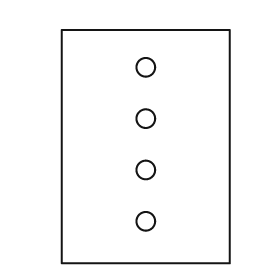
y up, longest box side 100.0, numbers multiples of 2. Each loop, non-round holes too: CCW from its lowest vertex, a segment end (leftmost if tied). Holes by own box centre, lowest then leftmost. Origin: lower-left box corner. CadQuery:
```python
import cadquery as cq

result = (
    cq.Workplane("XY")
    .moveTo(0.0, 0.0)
    .lineTo(72.0, 0.0)
    .lineTo(72.0, 100.0)
    .lineTo(0.0, 100.0)
    .close()
    .moveTo(36.0, 18.0)
    .circle(4.0)
    .moveTo(36.0, 40.0)
    .circle(4.0)
    .moveTo(36.0, 62.0)
    .circle(4.0)
    .moveTo(36.0, 84.0)
    .circle(4.0)
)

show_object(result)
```